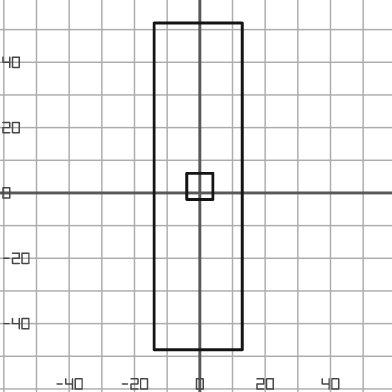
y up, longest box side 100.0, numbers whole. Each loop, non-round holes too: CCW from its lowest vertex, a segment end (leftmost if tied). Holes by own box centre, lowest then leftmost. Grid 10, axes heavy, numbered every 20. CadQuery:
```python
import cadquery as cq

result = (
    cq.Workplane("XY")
    .moveTo(-14.0, -48.0)
    .lineTo(13.0, -48.0)
    .lineTo(13.0, 52.0)
    .lineTo(-14.0, 52.0)
    .close()
    .moveTo(-4.0, -2.0)
    .lineTo(4.0, -2.0)
    .lineTo(4.0, 6.0)
    .lineTo(-4.0, 6.0)
    .close()
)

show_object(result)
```